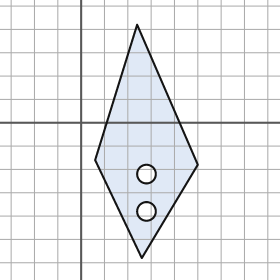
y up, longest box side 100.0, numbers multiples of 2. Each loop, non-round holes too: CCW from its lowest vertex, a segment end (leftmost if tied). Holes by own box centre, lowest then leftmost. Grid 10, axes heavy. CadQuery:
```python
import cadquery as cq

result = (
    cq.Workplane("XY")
    .moveTo(26.0, -58.0)
    .lineTo(50.0, -18.0)
    .lineTo(24.0, 42.0)
    .lineTo(6.0, -16.0)
    .close()
    .moveTo(28.0, -38.0)
    .circle(4.0)
    .moveTo(28.0, -22.0)
    .circle(4.0)
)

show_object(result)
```